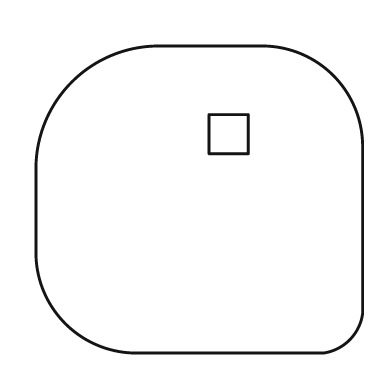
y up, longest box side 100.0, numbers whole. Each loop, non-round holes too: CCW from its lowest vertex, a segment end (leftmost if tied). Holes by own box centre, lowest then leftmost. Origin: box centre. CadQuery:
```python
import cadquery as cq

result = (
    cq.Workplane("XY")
    .moveTo(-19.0, -47.0)
    .lineTo(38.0, -47.0)
    .threePointArc((46.0, -43.0), (50.0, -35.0))
    .lineTo(50.0, 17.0)
    .threePointArc((41.0, 38.0), (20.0, 47.0))
    .lineTo(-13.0, 47.0)
    .threePointArc((-39.0, 36.0), (-50.0, 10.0))
    .lineTo(-50.0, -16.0)
    .threePointArc((-41.0, -38.0), (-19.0, -47.0))
    .close()
    .moveTo(3.0, 14.0)
    .lineTo(15.0, 14.0)
    .lineTo(15.0, 26.0)
    .lineTo(3.0, 26.0)
    .close()
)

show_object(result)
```